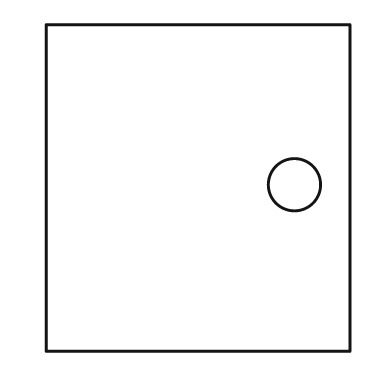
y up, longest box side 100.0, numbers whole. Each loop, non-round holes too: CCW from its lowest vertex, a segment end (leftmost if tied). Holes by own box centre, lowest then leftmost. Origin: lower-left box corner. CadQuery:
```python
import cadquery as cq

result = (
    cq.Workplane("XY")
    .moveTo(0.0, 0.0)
    .lineTo(93.0, 0.0)
    .lineTo(93.0, 100.0)
    .lineTo(0.0, 100.0)
    .close()
    .moveTo(76.0, 51.0)
    .circle(8.0)
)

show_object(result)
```